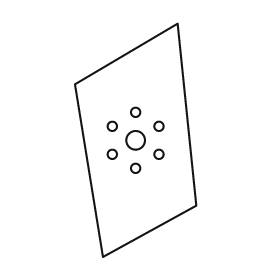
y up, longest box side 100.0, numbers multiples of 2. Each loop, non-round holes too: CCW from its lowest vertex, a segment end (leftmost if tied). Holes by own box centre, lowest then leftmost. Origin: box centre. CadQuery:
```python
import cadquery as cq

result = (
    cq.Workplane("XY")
    .moveTo(-14.0, -50.0)
    .lineTo(26.0, -28.0)
    .lineTo(18.0, 50.0)
    .lineTo(-26.0, 24.0)
    .close()
    .moveTo(0.0, -12.0)
    .circle(2.0)
    .moveTo(-10.0, -6.0)
    .circle(2.0)
    .moveTo(10.0, -6.0)
    .circle(2.0)
    .moveTo(0.0, 0.0)
    .circle(4.0)
    .moveTo(-10.0, 6.0)
    .circle(2.0)
    .moveTo(10.0, 6.0)
    .circle(2.0)
    .moveTo(0.0, 12.0)
    .circle(2.0)
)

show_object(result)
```